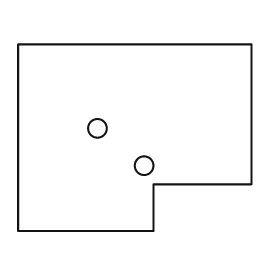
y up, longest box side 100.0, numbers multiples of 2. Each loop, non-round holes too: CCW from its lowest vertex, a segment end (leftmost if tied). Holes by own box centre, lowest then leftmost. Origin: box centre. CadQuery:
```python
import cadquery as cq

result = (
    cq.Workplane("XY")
    .moveTo(-50.0, -40.0)
    .lineTo(8.0, -40.0)
    .lineTo(8.0, -20.0)
    .lineTo(50.0, -20.0)
    .lineTo(50.0, 40.0)
    .lineTo(-50.0, 40.0)
    .close()
    .moveTo(4.0, -12.0)
    .circle(4.0)
    .moveTo(-16.0, 4.0)
    .circle(4.0)
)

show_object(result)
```